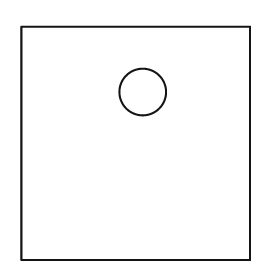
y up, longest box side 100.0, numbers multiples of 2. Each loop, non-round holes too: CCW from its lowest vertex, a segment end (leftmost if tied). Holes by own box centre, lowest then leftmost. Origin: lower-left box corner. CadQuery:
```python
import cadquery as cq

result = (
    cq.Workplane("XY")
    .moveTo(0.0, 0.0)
    .lineTo(98.0, 0.0)
    .lineTo(98.0, 100.0)
    .lineTo(0.0, 100.0)
    .close()
    .moveTo(52.0, 72.0)
    .circle(10.0)
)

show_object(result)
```